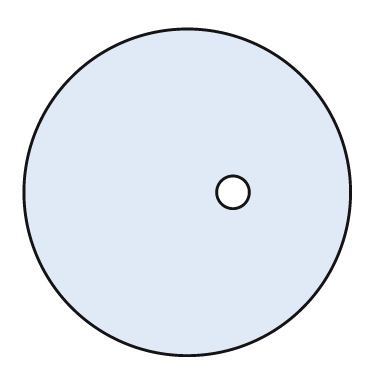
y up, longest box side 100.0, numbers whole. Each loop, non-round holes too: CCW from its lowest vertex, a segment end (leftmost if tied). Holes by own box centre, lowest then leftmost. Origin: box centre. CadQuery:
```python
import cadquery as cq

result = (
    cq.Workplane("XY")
    .moveTo(0.0, 0.0)
    .circle(50.0)
    .moveTo(14.0, 0.0)
    .circle(5.0)
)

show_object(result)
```